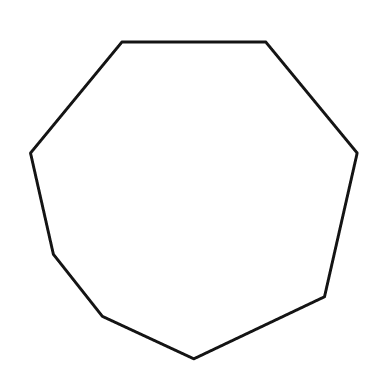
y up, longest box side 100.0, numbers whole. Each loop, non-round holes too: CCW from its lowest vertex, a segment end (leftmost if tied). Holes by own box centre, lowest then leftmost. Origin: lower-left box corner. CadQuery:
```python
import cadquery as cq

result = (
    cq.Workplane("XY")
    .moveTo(50.0, 0.0)
    .lineTo(90.0, 19.0)
    .lineTo(100.0, 63.0)
    .lineTo(72.0, 97.0)
    .lineTo(28.0, 97.0)
    .lineTo(0.0, 63.0)
    .lineTo(7.0, 32.0)
    .lineTo(22.0, 13.0)
    .close()
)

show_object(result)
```